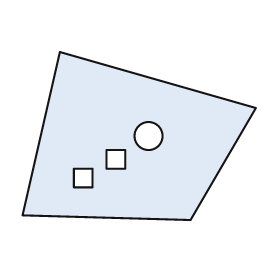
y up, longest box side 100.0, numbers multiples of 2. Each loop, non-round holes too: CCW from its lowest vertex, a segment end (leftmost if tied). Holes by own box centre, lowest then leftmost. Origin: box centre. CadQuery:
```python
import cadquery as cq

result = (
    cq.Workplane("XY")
    .moveTo(22.0, -36.0)
    .lineTo(50.0, 12.0)
    .lineTo(-34.0, 36.0)
    .lineTo(-50.0, -34.0)
    .close()
    .moveTo(-28.0, -22.0)
    .lineTo(-20.0, -22.0)
    .lineTo(-20.0, -14.0)
    .lineTo(-28.0, -14.0)
    .close()
    .moveTo(-14.0, -14.0)
    .lineTo(-6.0, -14.0)
    .lineTo(-6.0, -6.0)
    .lineTo(-14.0, -6.0)
    .close()
    .moveTo(4.0, 0.0)
    .circle(6.0)
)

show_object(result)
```